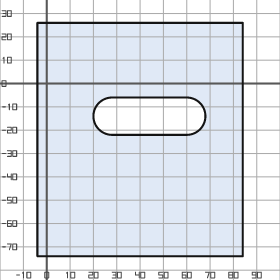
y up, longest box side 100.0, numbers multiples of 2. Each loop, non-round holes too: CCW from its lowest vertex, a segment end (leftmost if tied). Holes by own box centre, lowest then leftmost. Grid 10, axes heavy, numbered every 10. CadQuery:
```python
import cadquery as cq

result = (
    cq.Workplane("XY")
    .moveTo(-4.0, -74.0)
    .lineTo(84.0, -74.0)
    .lineTo(84.0, 26.0)
    .lineTo(-4.0, 26.0)
    .close()
    .moveTo(28.0, -22.0)
    .lineTo(60.0, -22.0)
    .threePointArc((68.0, -14.0), (60.0, -6.0))
    .lineTo(28.0, -6.0)
    .threePointArc((20.0, -14.0), (28.0, -22.0))
    .close()
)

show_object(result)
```